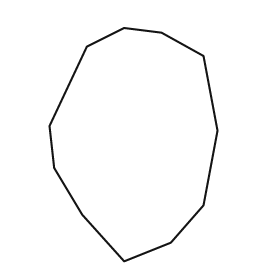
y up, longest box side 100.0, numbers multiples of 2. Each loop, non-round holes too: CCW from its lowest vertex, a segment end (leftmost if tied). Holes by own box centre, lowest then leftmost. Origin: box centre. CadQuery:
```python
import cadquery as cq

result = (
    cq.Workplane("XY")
    .moveTo(-4.0, -50.0)
    .lineTo(16.0, -42.0)
    .lineTo(30.0, -26.0)
    .lineTo(36.0, 6.0)
    .lineTo(30.0, 38.0)
    .lineTo(12.0, 48.0)
    .lineTo(-4.0, 50.0)
    .lineTo(-20.0, 42.0)
    .lineTo(-36.0, 8.0)
    .lineTo(-34.0, -10.0)
    .lineTo(-22.0, -30.0)
    .close()
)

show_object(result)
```